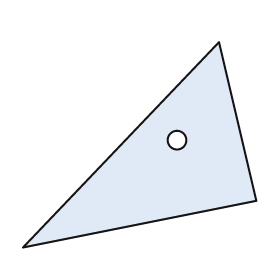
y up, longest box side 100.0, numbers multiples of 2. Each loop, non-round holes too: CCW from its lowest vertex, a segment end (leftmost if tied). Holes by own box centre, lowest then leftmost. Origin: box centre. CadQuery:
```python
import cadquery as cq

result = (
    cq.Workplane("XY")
    .moveTo(-50.0, -44.0)
    .lineTo(50.0, -24.0)
    .lineTo(34.0, 44.0)
    .close()
    .moveTo(16.0, 2.0)
    .circle(4.0)
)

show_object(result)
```